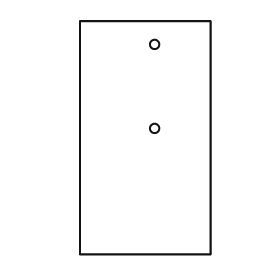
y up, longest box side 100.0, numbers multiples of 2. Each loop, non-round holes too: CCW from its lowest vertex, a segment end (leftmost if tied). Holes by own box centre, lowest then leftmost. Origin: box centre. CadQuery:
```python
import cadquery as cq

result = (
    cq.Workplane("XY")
    .moveTo(-28.0, -50.0)
    .lineTo(28.0, -50.0)
    .lineTo(28.0, 50.0)
    .lineTo(-28.0, 50.0)
    .close()
    .moveTo(4.0, 4.0)
    .circle(2.0)
    .moveTo(4.0, 40.0)
    .circle(2.0)
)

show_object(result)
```